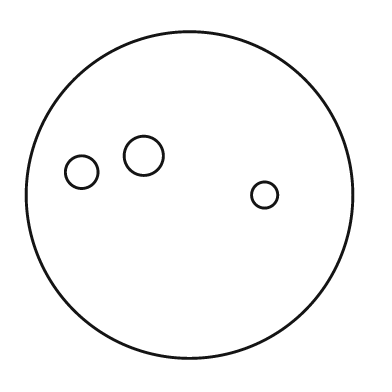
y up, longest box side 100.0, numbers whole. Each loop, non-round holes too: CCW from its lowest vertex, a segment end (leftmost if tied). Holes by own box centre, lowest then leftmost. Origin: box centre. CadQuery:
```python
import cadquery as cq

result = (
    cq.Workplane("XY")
    .moveTo(0.0, 0.0)
    .circle(50.0)
    .moveTo(23.0, 0.0)
    .circle(4.0)
    .moveTo(-33.0, 7.0)
    .circle(5.0)
    .moveTo(-14.0, 12.0)
    .circle(6.0)
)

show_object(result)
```